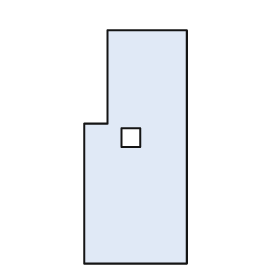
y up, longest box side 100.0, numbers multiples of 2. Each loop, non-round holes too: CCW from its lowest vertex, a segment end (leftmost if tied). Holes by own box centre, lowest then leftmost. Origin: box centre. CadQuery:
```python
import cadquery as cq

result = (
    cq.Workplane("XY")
    .moveTo(-22.0, -50.0)
    .lineTo(22.0, -50.0)
    .lineTo(22.0, 50.0)
    .lineTo(-12.0, 50.0)
    .lineTo(-12.0, 10.0)
    .lineTo(-22.0, 10.0)
    .close()
    .moveTo(-6.0, 0.0)
    .lineTo(2.0, 0.0)
    .lineTo(2.0, 8.0)
    .lineTo(-6.0, 8.0)
    .close()
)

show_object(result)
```